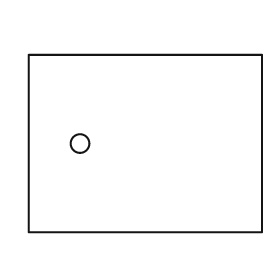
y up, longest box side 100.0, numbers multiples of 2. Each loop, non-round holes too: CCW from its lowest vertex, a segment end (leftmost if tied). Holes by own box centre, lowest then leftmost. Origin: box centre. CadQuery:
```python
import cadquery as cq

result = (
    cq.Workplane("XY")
    .moveTo(-50.0, -38.0)
    .lineTo(50.0, -38.0)
    .lineTo(50.0, 38.0)
    .lineTo(-50.0, 38.0)
    .close()
    .moveTo(-28.0, 0.0)
    .circle(4.0)
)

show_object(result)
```